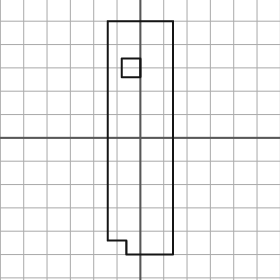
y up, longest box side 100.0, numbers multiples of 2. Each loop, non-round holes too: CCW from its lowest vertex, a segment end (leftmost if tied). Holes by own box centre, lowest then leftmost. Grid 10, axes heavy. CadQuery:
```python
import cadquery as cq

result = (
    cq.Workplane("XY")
    .moveTo(-6.0, -50.0)
    .lineTo(14.0, -50.0)
    .lineTo(14.0, 50.0)
    .lineTo(-14.0, 50.0)
    .lineTo(-14.0, -44.0)
    .lineTo(-6.0, -44.0)
    .close()
    .moveTo(-8.0, 26.0)
    .lineTo(0.0, 26.0)
    .lineTo(0.0, 34.0)
    .lineTo(-8.0, 34.0)
    .close()
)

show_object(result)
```